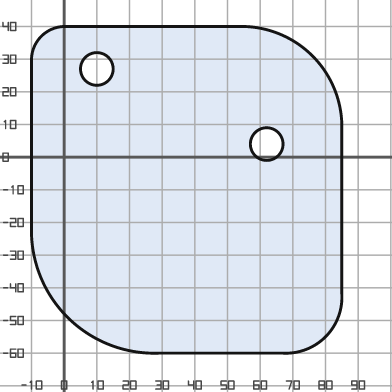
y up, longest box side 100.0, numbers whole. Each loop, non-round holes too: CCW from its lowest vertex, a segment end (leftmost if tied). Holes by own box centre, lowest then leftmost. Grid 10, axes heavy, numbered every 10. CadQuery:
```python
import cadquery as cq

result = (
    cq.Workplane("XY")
    .moveTo(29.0, -60.0)
    .lineTo(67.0, -60.0)
    .threePointArc((80.0, -55.0), (85.0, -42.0))
    .lineTo(85.0, 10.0)
    .threePointArc((76.0, 31.0), (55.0, 40.0))
    .lineTo(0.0, 40.0)
    .threePointArc((-7.0, 37.0), (-10.0, 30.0))
    .lineTo(-10.0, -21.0)
    .threePointArc((1.0, -49.0), (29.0, -60.0))
    .close()
    .moveTo(62.0, 4.0)
    .circle(5.0)
    .moveTo(10.0, 27.0)
    .circle(5.0)
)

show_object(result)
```